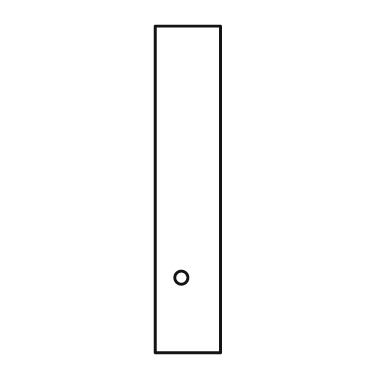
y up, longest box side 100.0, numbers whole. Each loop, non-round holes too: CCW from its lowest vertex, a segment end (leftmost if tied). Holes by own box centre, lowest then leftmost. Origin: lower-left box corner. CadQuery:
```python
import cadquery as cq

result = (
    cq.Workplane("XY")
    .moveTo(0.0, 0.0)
    .lineTo(20.0, 0.0)
    .lineTo(20.0, 100.0)
    .lineTo(0.0, 100.0)
    .close()
    .moveTo(8.0, 23.0)
    .circle(2.0)
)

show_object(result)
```